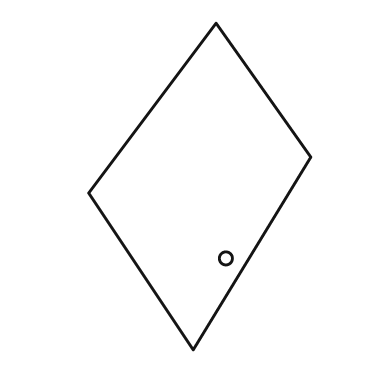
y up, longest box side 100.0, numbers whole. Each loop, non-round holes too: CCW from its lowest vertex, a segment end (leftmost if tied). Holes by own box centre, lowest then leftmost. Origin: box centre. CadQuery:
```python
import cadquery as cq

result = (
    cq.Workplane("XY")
    .moveTo(-2.0, -50.0)
    .lineTo(34.0, 9.0)
    .lineTo(5.0, 50.0)
    .lineTo(-34.0, -2.0)
    .close()
    .moveTo(8.0, -22.0)
    .circle(2.0)
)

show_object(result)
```